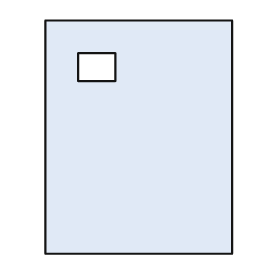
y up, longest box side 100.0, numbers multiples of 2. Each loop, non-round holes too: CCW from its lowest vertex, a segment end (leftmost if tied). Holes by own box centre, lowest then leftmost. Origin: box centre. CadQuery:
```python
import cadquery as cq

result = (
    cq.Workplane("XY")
    .moveTo(-40.0, -50.0)
    .lineTo(40.0, -50.0)
    .lineTo(40.0, 50.0)
    .lineTo(-40.0, 50.0)
    .close()
    .moveTo(-26.0, 24.0)
    .lineTo(-10.0, 24.0)
    .lineTo(-10.0, 36.0)
    .lineTo(-26.0, 36.0)
    .close()
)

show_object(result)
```